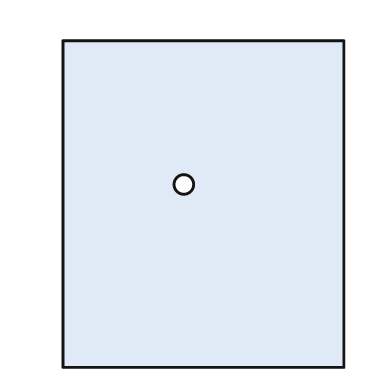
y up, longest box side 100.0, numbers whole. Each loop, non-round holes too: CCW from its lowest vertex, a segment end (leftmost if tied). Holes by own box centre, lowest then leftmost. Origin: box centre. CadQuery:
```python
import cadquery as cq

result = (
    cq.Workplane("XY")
    .moveTo(-43.0, -50.0)
    .lineTo(43.0, -50.0)
    .lineTo(43.0, 50.0)
    .lineTo(-43.0, 50.0)
    .close()
    .moveTo(-6.0, 6.0)
    .circle(3.0)
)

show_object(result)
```